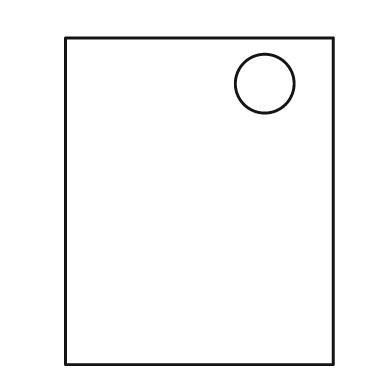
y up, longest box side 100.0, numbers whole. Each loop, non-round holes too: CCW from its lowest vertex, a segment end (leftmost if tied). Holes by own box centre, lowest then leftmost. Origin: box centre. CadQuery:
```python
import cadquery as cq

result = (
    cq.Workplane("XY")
    .moveTo(-41.0, -50.0)
    .lineTo(41.0, -50.0)
    .lineTo(41.0, 50.0)
    .lineTo(-41.0, 50.0)
    .close()
    .moveTo(20.0, 36.0)
    .circle(9.0)
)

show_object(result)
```